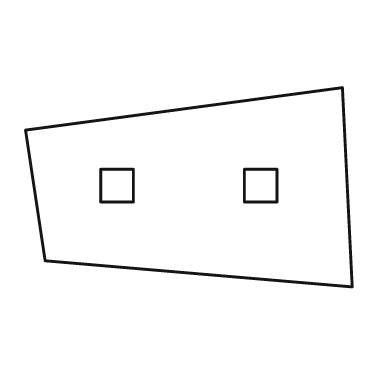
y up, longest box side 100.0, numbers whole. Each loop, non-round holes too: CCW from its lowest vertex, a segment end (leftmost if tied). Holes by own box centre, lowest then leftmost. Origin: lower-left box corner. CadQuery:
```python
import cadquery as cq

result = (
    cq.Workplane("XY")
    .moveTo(100.0, 0.0)
    .lineTo(97.0, 61.0)
    .lineTo(0.0, 48.0)
    .lineTo(6.0, 8.0)
    .close()
    .moveTo(23.0, 26.0)
    .lineTo(33.0, 26.0)
    .lineTo(33.0, 36.0)
    .lineTo(23.0, 36.0)
    .close()
    .moveTo(67.0, 26.0)
    .lineTo(77.0, 26.0)
    .lineTo(77.0, 36.0)
    .lineTo(67.0, 36.0)
    .close()
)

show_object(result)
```